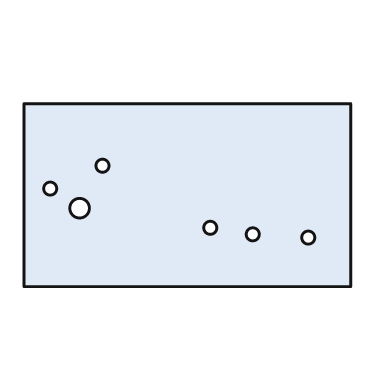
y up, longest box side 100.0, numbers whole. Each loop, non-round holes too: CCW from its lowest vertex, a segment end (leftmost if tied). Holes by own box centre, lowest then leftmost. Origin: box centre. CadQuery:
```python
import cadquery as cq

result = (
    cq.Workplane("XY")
    .moveTo(-50.0, -28.0)
    .lineTo(50.0, -28.0)
    .lineTo(50.0, 28.0)
    .lineTo(-50.0, 28.0)
    .close()
    .moveTo(37.0, -13.0)
    .circle(2.0)
    .moveTo(20.0, -12.0)
    .circle(2.0)
    .moveTo(7.0, -10.0)
    .circle(2.0)
    .moveTo(-33.0, -4.0)
    .circle(3.0)
    .moveTo(-42.0, 2.0)
    .circle(2.0)
    .moveTo(-26.0, 9.0)
    .circle(2.0)
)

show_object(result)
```